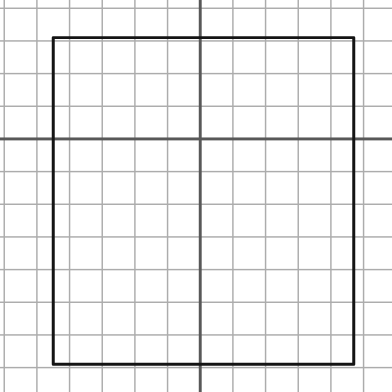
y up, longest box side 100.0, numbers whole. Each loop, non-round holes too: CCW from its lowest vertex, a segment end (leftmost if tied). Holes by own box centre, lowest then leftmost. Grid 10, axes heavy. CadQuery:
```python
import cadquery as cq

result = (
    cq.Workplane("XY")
    .moveTo(-45.0, -69.0)
    .lineTo(47.0, -69.0)
    .lineTo(47.0, 31.0)
    .lineTo(-45.0, 31.0)
    .close()
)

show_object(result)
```